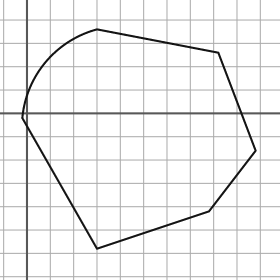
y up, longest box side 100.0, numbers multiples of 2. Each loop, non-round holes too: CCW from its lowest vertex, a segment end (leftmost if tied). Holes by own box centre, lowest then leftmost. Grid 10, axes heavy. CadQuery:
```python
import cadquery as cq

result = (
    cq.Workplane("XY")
    .moveTo(30.0, -58.0)
    .lineTo(78.0, -42.0)
    .lineTo(98.0, -16.0)
    .lineTo(82.0, 26.0)
    .lineTo(30.0, 36.0)
    .threePointArc((8.0, 22.0), (-2.0, -2.0))
    .close()
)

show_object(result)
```